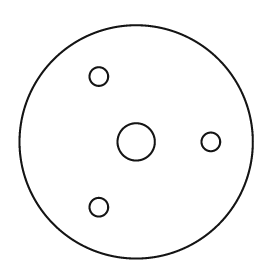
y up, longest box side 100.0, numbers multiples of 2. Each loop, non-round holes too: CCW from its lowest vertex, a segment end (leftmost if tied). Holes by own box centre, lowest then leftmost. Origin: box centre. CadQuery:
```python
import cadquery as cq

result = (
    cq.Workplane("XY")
    .moveTo(0.0, 0.0)
    .circle(50.0)
    .moveTo(-16.0, -28.0)
    .circle(4.0)
    .moveTo(0.0, 0.0)
    .circle(8.0)
    .moveTo(32.0, 0.0)
    .circle(4.0)
    .moveTo(-16.0, 28.0)
    .circle(4.0)
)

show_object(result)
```